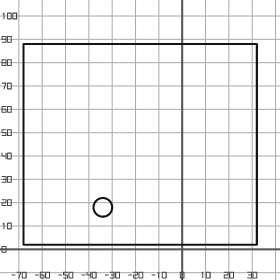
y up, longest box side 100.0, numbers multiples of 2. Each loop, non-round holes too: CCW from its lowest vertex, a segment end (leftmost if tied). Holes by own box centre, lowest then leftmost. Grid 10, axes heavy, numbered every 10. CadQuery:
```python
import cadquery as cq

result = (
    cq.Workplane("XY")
    .moveTo(-68.0, 2.0)
    .lineTo(32.0, 2.0)
    .lineTo(32.0, 88.0)
    .lineTo(-68.0, 88.0)
    .close()
    .moveTo(-34.0, 18.0)
    .circle(4.0)
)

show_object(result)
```